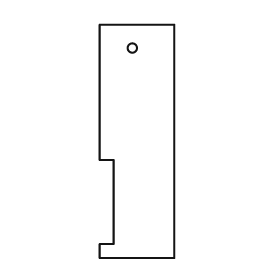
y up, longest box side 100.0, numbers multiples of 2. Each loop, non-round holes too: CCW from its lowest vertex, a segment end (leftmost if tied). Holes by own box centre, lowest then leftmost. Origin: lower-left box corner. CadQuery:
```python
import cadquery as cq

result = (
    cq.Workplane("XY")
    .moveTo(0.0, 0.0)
    .lineTo(32.0, 0.0)
    .lineTo(32.0, 100.0)
    .lineTo(0.0, 100.0)
    .lineTo(0.0, 42.0)
    .lineTo(6.0, 42.0)
    .lineTo(6.0, 6.0)
    .lineTo(0.0, 6.0)
    .close()
    .moveTo(14.0, 90.0)
    .circle(2.0)
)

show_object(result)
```